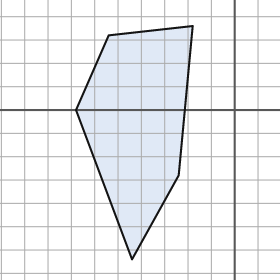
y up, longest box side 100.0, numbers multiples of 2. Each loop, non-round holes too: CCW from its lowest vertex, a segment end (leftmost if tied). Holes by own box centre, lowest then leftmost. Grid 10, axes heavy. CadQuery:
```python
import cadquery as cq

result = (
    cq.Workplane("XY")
    .moveTo(-44.0, -64.0)
    .lineTo(-24.0, -28.0)
    .lineTo(-18.0, 36.0)
    .lineTo(-54.0, 32.0)
    .lineTo(-68.0, 0.0)
    .close()
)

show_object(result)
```